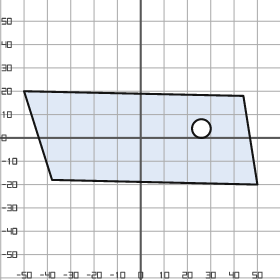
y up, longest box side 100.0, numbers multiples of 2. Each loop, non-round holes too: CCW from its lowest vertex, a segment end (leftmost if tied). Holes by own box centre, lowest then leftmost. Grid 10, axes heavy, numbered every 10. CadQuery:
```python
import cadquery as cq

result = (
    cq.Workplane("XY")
    .moveTo(50.0, -20.0)
    .lineTo(44.0, 18.0)
    .lineTo(-50.0, 20.0)
    .lineTo(-38.0, -18.0)
    .close()
    .moveTo(26.0, 4.0)
    .circle(4.0)
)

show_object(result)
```